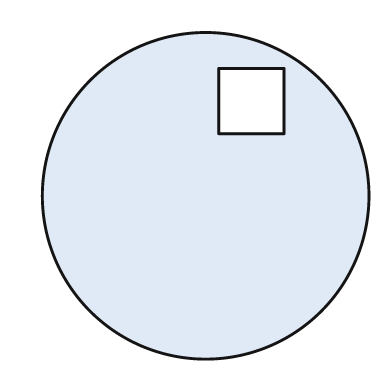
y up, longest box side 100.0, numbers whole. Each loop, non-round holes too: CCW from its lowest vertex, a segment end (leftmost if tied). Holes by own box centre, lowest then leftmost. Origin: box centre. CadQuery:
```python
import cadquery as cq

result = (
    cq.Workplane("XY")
    .moveTo(0.0, 0.0)
    .circle(50.0)
    .moveTo(4.0, 19.0)
    .lineTo(24.0, 19.0)
    .lineTo(24.0, 39.0)
    .lineTo(4.0, 39.0)
    .close()
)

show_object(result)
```